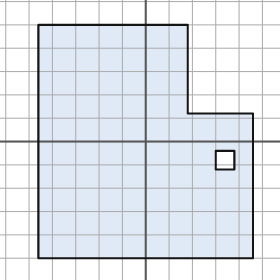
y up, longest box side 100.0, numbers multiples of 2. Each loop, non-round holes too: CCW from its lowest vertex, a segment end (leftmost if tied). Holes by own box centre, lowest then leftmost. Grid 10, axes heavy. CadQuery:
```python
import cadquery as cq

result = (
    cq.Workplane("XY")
    .moveTo(-46.0, -50.0)
    .lineTo(46.0, -50.0)
    .lineTo(46.0, 12.0)
    .lineTo(18.0, 12.0)
    .lineTo(18.0, 50.0)
    .lineTo(-46.0, 50.0)
    .close()
    .moveTo(30.0, -12.0)
    .lineTo(38.0, -12.0)
    .lineTo(38.0, -4.0)
    .lineTo(30.0, -4.0)
    .close()
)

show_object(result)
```